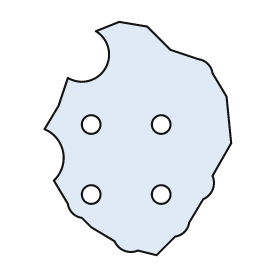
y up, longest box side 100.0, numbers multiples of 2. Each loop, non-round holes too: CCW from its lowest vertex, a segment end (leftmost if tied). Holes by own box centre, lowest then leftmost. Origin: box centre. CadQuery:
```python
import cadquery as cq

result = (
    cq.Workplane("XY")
    .moveTo(8.0, -50.0)
    .lineTo(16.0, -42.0)
    .threePointArc((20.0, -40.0), (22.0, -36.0))
    .lineTo(28.0, -26.0)
    .threePointArc((32.0, -22.0), (32.0, -16.0))
    .lineTo(40.0, -2.0)
    .lineTo(38.0, 18.0)
    .lineTo(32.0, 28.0)
    .threePointArc((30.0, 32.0), (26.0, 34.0))
    .lineTo(14.0, 38.0)
    .lineTo(4.0, 48.0)
    .lineTo(-8.0, 50.0)
    .lineTo(-18.0, 46.0)
    .threePointArc((-14.0, 30.0), (-30.0, 26.0))
    .lineTo(-34.0, 14.0)
    .lineTo(-40.0, 4.0)
    .threePointArc((-32.0, -6.0), (-36.0, -18.0))
    .lineTo(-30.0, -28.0)
    .threePointArc((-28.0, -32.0), (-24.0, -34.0))
    .lineTo(-20.0, -38.0)
    .lineTo(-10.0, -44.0)
    .threePointArc((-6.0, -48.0), (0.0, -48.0))
    .close()
    .moveTo(-20.0, -24.0)
    .circle(4.0)
    .moveTo(10.0, -24.0)
    .circle(4.0)
    .moveTo(-20.0, 6.0)
    .circle(4.0)
    .moveTo(10.0, 6.0)
    .circle(4.0)
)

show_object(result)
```